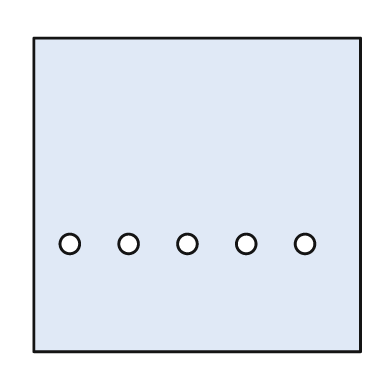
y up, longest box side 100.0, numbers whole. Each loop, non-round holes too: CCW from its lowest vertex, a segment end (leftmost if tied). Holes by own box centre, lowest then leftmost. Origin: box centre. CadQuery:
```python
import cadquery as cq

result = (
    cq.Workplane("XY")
    .moveTo(-50.0, -48.0)
    .lineTo(50.0, -48.0)
    .lineTo(50.0, 48.0)
    .lineTo(-50.0, 48.0)
    .close()
    .moveTo(-39.0, -15.0)
    .circle(3.0)
    .moveTo(-21.0, -15.0)
    .circle(3.0)
    .moveTo(-3.0, -15.0)
    .circle(3.0)
    .moveTo(15.0, -15.0)
    .circle(3.0)
    .moveTo(33.0, -15.0)
    .circle(3.0)
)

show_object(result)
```